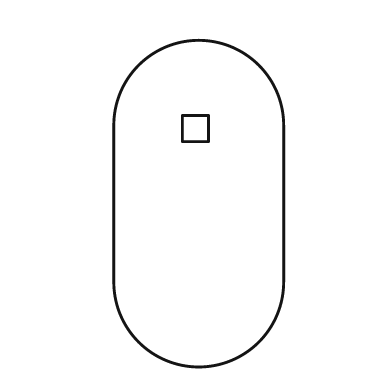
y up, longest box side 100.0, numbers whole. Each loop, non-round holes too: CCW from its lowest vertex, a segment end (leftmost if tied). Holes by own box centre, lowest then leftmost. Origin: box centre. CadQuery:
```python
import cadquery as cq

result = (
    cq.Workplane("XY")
    .moveTo(-26.0, -24.0)
    .threePointArc((0.0, -50.0), (26.0, -24.0))
    .lineTo(26.0, 24.0)
    .threePointArc((0.0, 50.0), (-26.0, 24.0))
    .close()
    .moveTo(-5.0, 19.0)
    .lineTo(3.0, 19.0)
    .lineTo(3.0, 27.0)
    .lineTo(-5.0, 27.0)
    .close()
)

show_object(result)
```